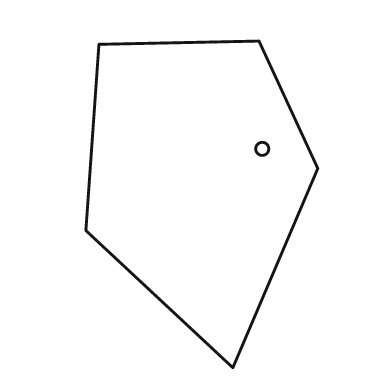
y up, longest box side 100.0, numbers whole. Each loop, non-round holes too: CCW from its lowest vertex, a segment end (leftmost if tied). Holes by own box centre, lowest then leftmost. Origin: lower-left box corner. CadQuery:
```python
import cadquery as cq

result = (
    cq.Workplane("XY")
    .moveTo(45.0, 0.0)
    .lineTo(71.0, 61.0)
    .lineTo(53.0, 100.0)
    .lineTo(4.0, 99.0)
    .lineTo(0.0, 42.0)
    .close()
    .moveTo(54.0, 67.0)
    .circle(2.0)
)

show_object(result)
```